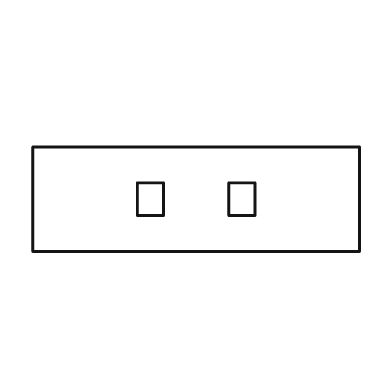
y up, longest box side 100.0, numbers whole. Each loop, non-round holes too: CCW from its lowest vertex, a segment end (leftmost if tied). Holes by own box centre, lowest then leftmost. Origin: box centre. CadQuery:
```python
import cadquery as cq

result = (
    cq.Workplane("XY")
    .moveTo(-50.0, -16.0)
    .lineTo(50.0, -16.0)
    .lineTo(50.0, 16.0)
    .lineTo(-50.0, 16.0)
    .close()
    .moveTo(-18.0, -5.0)
    .lineTo(-10.0, -5.0)
    .lineTo(-10.0, 5.0)
    .lineTo(-18.0, 5.0)
    .close()
    .moveTo(10.0, -5.0)
    .lineTo(18.0, -5.0)
    .lineTo(18.0, 5.0)
    .lineTo(10.0, 5.0)
    .close()
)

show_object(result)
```